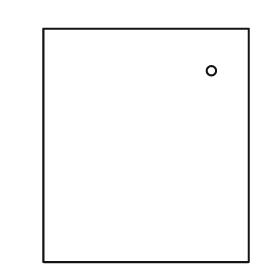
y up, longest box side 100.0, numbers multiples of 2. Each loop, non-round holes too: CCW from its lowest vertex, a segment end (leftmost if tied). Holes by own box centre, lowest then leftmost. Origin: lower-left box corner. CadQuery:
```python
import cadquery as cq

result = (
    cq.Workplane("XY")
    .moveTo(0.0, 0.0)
    .lineTo(88.0, 0.0)
    .lineTo(88.0, 100.0)
    .lineTo(0.0, 100.0)
    .close()
    .moveTo(72.0, 82.0)
    .circle(2.0)
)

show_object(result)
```